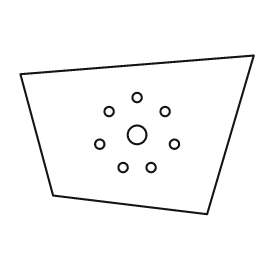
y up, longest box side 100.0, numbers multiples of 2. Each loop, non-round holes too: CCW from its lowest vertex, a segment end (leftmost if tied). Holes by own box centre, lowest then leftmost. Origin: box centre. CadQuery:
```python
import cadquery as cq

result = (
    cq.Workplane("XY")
    .moveTo(30.0, -34.0)
    .lineTo(50.0, 34.0)
    .lineTo(-50.0, 26.0)
    .lineTo(-36.0, -26.0)
    .close()
    .moveTo(-6.0, -14.0)
    .circle(2.0)
    .moveTo(6.0, -14.0)
    .circle(2.0)
    .moveTo(-16.0, -4.0)
    .circle(2.0)
    .moveTo(16.0, -4.0)
    .circle(2.0)
    .moveTo(0.0, 0.0)
    .circle(4.0)
    .moveTo(-12.0, 10.0)
    .circle(2.0)
    .moveTo(12.0, 10.0)
    .circle(2.0)
    .moveTo(0.0, 16.0)
    .circle(2.0)
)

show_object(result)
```